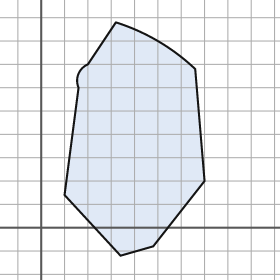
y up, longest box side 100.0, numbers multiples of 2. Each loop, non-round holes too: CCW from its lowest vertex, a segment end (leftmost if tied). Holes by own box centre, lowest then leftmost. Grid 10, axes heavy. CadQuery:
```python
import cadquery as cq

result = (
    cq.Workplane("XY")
    .moveTo(34.0, -12.0)
    .lineTo(48.0, -8.0)
    .lineTo(70.0, 20.0)
    .lineTo(66.0, 68.0)
    .threePointArc((50.0, 80.0), (32.0, 88.0))
    .lineTo(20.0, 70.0)
    .threePointArc((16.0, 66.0), (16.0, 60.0))
    .lineTo(10.0, 14.0)
    .close()
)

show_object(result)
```